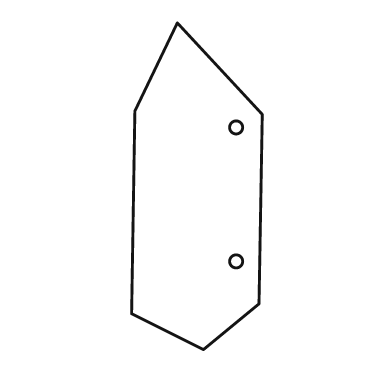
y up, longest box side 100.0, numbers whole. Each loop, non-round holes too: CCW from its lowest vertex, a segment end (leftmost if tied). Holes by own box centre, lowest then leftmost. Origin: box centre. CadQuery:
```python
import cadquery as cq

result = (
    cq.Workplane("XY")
    .moveTo(2.0, -50.0)
    .lineTo(19.0, -36.0)
    .lineTo(20.0, 22.0)
    .lineTo(-6.0, 50.0)
    .lineTo(-19.0, 23.0)
    .lineTo(-20.0, -39.0)
    .close()
    .moveTo(12.0, -23.0)
    .circle(2.0)
    .moveTo(12.0, 18.0)
    .circle(2.0)
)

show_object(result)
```